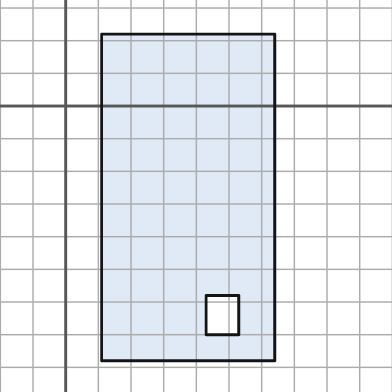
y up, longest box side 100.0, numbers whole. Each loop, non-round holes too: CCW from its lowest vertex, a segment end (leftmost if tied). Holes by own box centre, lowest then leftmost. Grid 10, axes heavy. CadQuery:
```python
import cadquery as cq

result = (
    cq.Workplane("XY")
    .moveTo(11.0, -78.0)
    .lineTo(64.0, -78.0)
    .lineTo(64.0, 22.0)
    .lineTo(11.0, 22.0)
    .close()
    .moveTo(43.0, -70.0)
    .lineTo(53.0, -70.0)
    .lineTo(53.0, -58.0)
    .lineTo(43.0, -58.0)
    .close()
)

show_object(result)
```